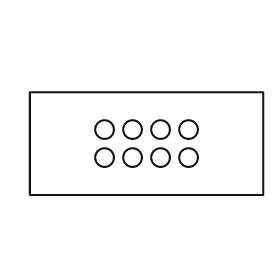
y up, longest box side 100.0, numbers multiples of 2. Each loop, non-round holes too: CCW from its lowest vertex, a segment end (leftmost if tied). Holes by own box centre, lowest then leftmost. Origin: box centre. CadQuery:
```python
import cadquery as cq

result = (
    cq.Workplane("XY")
    .moveTo(-50.0, -22.0)
    .lineTo(50.0, -22.0)
    .lineTo(50.0, 22.0)
    .lineTo(-50.0, 22.0)
    .close()
    .moveTo(-18.0, -6.0)
    .circle(4.0)
    .moveTo(-6.0, -6.0)
    .circle(4.0)
    .moveTo(6.0, -6.0)
    .circle(4.0)
    .moveTo(18.0, -6.0)
    .circle(4.0)
    .moveTo(-18.0, 6.0)
    .circle(4.0)
    .moveTo(-6.0, 6.0)
    .circle(4.0)
    .moveTo(6.0, 6.0)
    .circle(4.0)
    .moveTo(18.0, 6.0)
    .circle(4.0)
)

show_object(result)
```